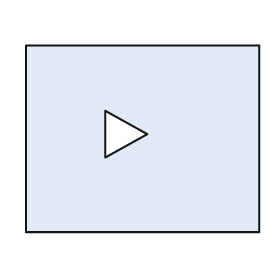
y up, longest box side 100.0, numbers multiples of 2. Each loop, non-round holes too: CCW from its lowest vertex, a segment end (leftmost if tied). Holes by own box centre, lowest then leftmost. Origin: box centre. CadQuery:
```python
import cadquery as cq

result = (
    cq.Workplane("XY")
    .moveTo(-50.0, -40.0)
    .lineTo(50.0, -40.0)
    .lineTo(50.0, 40.0)
    .lineTo(-50.0, 40.0)
    .close()
    .moveTo(-16.0, -8.0)
    .lineTo(2.0, 2.0)
    .lineTo(-16.0, 12.0)
    .close()
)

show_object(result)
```